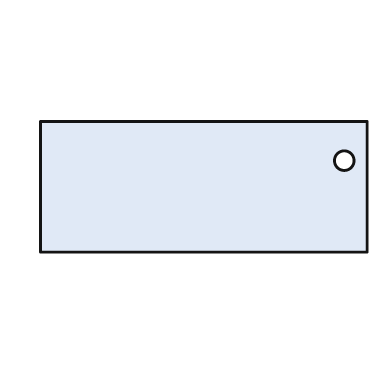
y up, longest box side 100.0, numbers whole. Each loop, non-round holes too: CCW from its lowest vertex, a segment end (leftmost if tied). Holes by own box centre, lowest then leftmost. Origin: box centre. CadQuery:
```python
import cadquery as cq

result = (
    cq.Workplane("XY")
    .moveTo(-50.0, -20.0)
    .lineTo(50.0, -20.0)
    .lineTo(50.0, 20.0)
    .lineTo(-50.0, 20.0)
    .close()
    .moveTo(43.0, 8.0)
    .circle(3.0)
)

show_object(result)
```